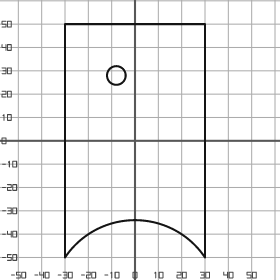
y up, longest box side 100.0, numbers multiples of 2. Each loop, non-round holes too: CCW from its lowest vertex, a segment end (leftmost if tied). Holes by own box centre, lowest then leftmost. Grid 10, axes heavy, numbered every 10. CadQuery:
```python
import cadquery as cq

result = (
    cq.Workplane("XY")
    .moveTo(-30.0, -50.0)
    .threePointArc((0.0, -34.0), (30.0, -50.0))
    .lineTo(30.0, 50.0)
    .lineTo(-30.0, 50.0)
    .close()
    .moveTo(-8.0, 28.0)
    .circle(4.0)
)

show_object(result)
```